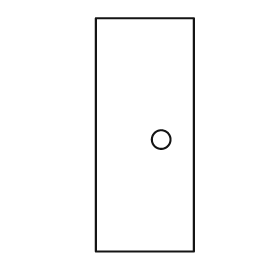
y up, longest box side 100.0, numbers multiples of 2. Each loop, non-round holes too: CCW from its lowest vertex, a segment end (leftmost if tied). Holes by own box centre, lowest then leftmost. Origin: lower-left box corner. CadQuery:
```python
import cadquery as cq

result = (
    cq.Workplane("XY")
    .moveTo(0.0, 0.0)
    .lineTo(42.0, 0.0)
    .lineTo(42.0, 100.0)
    .lineTo(0.0, 100.0)
    .close()
    .moveTo(28.0, 48.0)
    .circle(4.0)
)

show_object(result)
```